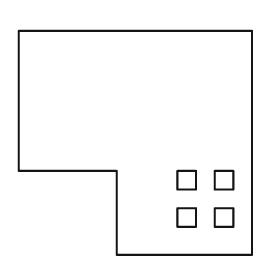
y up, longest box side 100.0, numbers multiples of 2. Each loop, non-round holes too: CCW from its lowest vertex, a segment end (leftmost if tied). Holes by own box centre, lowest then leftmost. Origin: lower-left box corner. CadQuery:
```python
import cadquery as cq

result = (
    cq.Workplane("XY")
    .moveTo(42.0, 0.0)
    .lineTo(100.0, 0.0)
    .lineTo(100.0, 96.0)
    .lineTo(0.0, 96.0)
    .lineTo(0.0, 36.0)
    .lineTo(42.0, 36.0)
    .close()
    .moveTo(68.0, 12.0)
    .lineTo(76.0, 12.0)
    .lineTo(76.0, 20.0)
    .lineTo(68.0, 20.0)
    .close()
    .moveTo(84.0, 12.0)
    .lineTo(92.0, 12.0)
    .lineTo(92.0, 20.0)
    .lineTo(84.0, 20.0)
    .close()
    .moveTo(68.0, 28.0)
    .lineTo(76.0, 28.0)
    .lineTo(76.0, 36.0)
    .lineTo(68.0, 36.0)
    .close()
    .moveTo(84.0, 28.0)
    .lineTo(92.0, 28.0)
    .lineTo(92.0, 36.0)
    .lineTo(84.0, 36.0)
    .close()
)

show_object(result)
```